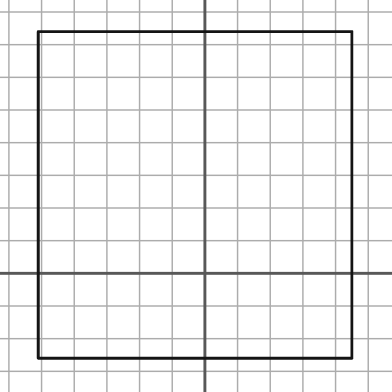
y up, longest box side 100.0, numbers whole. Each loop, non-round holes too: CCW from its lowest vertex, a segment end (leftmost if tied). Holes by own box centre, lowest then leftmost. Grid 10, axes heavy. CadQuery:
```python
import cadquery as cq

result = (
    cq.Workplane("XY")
    .moveTo(-51.0, -26.0)
    .lineTo(45.0, -26.0)
    .lineTo(45.0, 74.0)
    .lineTo(-51.0, 74.0)
    .close()
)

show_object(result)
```